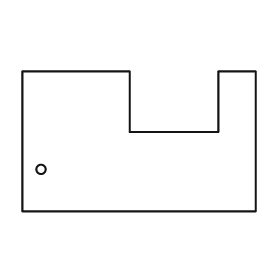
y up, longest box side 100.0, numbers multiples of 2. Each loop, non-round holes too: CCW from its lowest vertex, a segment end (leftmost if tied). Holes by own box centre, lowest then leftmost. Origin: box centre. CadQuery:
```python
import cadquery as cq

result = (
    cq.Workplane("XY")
    .moveTo(-50.0, -30.0)
    .lineTo(50.0, -30.0)
    .lineTo(50.0, 30.0)
    .lineTo(34.0, 30.0)
    .lineTo(34.0, 4.0)
    .lineTo(-4.0, 4.0)
    .lineTo(-4.0, 30.0)
    .lineTo(-50.0, 30.0)
    .close()
    .moveTo(-42.0, -12.0)
    .circle(2.0)
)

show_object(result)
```